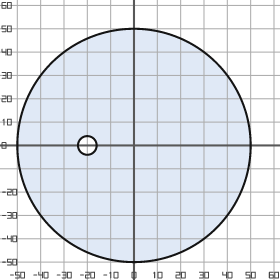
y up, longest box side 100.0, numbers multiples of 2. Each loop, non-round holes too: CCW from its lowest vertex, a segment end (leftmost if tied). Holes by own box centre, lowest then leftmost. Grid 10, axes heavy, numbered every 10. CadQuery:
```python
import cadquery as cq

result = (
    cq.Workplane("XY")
    .moveTo(0.0, 0.0)
    .circle(50.0)
    .moveTo(-20.0, 0.0)
    .circle(4.0)
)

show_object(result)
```